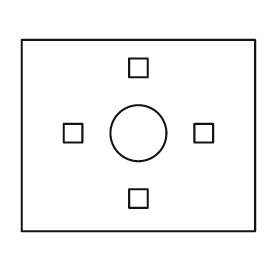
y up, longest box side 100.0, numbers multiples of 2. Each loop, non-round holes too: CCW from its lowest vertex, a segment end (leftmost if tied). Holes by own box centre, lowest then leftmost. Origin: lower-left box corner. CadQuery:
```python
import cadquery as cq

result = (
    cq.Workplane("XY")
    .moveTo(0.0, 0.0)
    .lineTo(100.0, 0.0)
    .lineTo(100.0, 82.0)
    .lineTo(0.0, 82.0)
    .close()
    .moveTo(46.0, 10.0)
    .lineTo(54.0, 10.0)
    .lineTo(54.0, 18.0)
    .lineTo(46.0, 18.0)
    .close()
    .moveTo(18.0, 38.0)
    .lineTo(26.0, 38.0)
    .lineTo(26.0, 46.0)
    .lineTo(18.0, 46.0)
    .close()
    .moveTo(50.0, 42.0)
    .circle(12.0)
    .moveTo(74.0, 38.0)
    .lineTo(82.0, 38.0)
    .lineTo(82.0, 46.0)
    .lineTo(74.0, 46.0)
    .close()
    .moveTo(46.0, 66.0)
    .lineTo(54.0, 66.0)
    .lineTo(54.0, 74.0)
    .lineTo(46.0, 74.0)
    .close()
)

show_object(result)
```